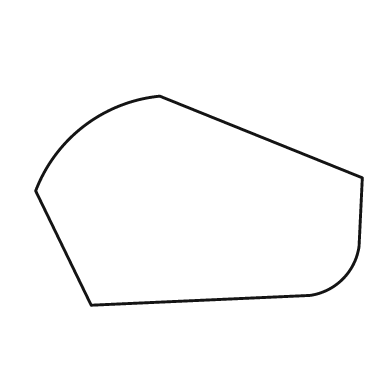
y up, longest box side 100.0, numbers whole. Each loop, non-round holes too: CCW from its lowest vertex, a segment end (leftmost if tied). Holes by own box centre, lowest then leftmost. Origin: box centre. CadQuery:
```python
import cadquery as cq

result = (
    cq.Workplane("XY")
    .moveTo(-33.0, -32.0)
    .lineTo(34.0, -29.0)
    .threePointArc((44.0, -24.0), (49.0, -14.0))
    .lineTo(50.0, 7.0)
    .lineTo(-12.0, 32.0)
    .threePointArc((-35.0, 23.0), (-50.0, 3.0))
    .close()
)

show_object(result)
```